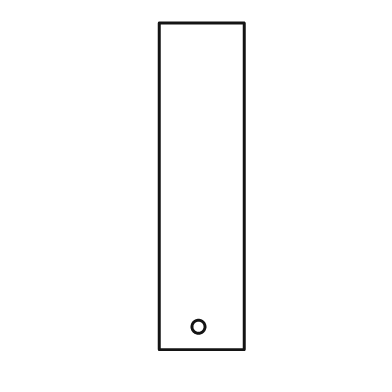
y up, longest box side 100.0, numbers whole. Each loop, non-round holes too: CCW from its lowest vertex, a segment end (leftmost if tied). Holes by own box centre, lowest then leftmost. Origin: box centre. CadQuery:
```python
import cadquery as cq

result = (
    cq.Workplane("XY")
    .moveTo(-13.0, -50.0)
    .lineTo(13.0, -50.0)
    .lineTo(13.0, 50.0)
    .lineTo(-13.0, 50.0)
    .close()
    .moveTo(-1.0, -43.0)
    .circle(2.0)
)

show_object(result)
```